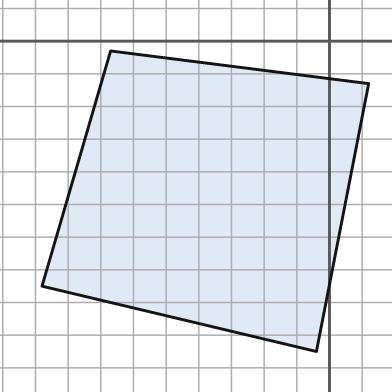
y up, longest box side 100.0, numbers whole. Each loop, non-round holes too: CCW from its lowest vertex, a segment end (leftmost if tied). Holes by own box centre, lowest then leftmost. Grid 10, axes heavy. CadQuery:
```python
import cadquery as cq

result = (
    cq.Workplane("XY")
    .moveTo(-4.0, -95.0)
    .lineTo(12.0, -13.0)
    .lineTo(-67.0, -3.0)
    .lineTo(-88.0, -75.0)
    .close()
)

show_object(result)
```